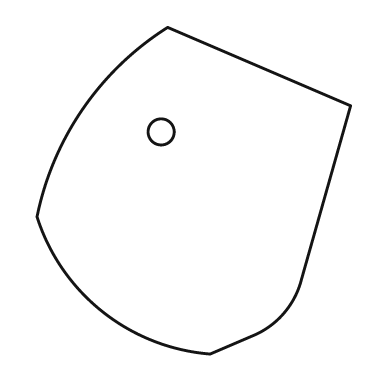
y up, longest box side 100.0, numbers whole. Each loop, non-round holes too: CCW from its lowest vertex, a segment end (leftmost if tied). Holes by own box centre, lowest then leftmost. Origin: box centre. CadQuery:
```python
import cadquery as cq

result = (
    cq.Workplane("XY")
    .moveTo(5.0, -50.0)
    .lineTo(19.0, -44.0)
    .threePointArc((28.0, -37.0), (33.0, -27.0))
    .lineTo(48.0, 26.0)
    .lineTo(-8.0, 50.0)
    .threePointArc((-34.0, 25.0), (-48.0, -8.0))
    .threePointArc((-28.0, -37.0), (5.0, -50.0))
    .close()
    .moveTo(-10.0, 18.0)
    .circle(4.0)
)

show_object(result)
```